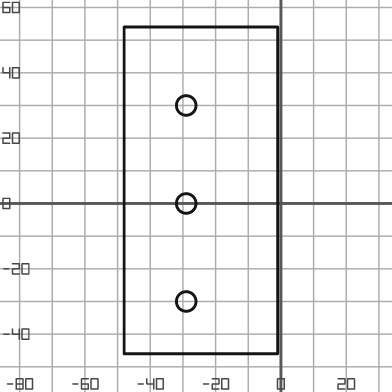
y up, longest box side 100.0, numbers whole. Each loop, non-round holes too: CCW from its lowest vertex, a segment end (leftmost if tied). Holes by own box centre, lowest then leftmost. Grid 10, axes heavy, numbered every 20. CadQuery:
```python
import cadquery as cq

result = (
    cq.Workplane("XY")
    .moveTo(-48.0, -46.0)
    .lineTo(-1.0, -46.0)
    .lineTo(-1.0, 54.0)
    .lineTo(-48.0, 54.0)
    .close()
    .moveTo(-29.0, -30.0)
    .circle(3.0)
    .moveTo(-29.0, 0.0)
    .circle(3.0)
    .moveTo(-29.0, 30.0)
    .circle(3.0)
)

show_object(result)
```